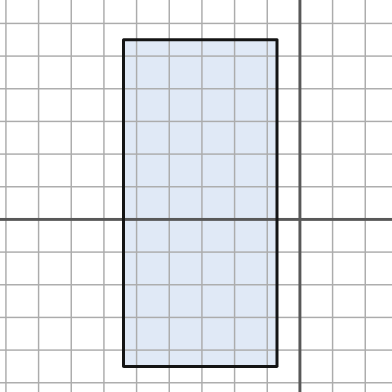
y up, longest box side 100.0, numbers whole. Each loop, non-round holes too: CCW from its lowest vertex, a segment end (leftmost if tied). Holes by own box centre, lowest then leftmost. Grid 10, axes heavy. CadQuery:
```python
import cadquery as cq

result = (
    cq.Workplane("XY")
    .moveTo(-54.0, -45.0)
    .lineTo(-7.0, -45.0)
    .lineTo(-7.0, 55.0)
    .lineTo(-54.0, 55.0)
    .close()
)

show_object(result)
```